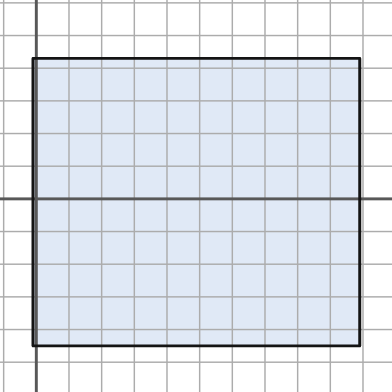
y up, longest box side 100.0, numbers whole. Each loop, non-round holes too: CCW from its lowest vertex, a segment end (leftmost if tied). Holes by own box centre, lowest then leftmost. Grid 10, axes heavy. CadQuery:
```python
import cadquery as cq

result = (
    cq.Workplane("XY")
    .moveTo(-1.0, -45.0)
    .lineTo(99.0, -45.0)
    .lineTo(99.0, 43.0)
    .lineTo(-1.0, 43.0)
    .close()
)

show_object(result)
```